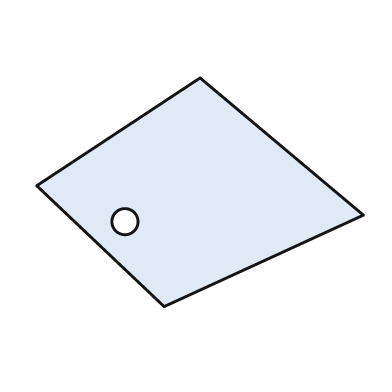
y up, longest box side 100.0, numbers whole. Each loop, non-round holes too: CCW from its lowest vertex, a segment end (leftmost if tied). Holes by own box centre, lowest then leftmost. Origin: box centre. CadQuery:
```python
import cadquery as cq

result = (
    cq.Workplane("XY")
    .moveTo(-11.0, -35.0)
    .lineTo(50.0, -7.0)
    .lineTo(0.0, 35.0)
    .lineTo(-50.0, 2.0)
    .close()
    .moveTo(-23.0, -9.0)
    .circle(4.0)
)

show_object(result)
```